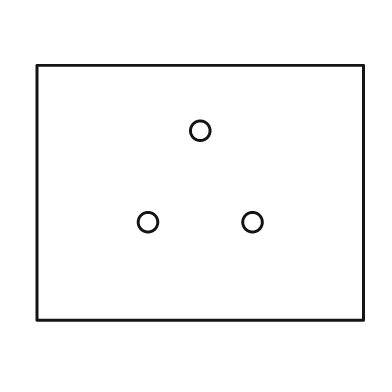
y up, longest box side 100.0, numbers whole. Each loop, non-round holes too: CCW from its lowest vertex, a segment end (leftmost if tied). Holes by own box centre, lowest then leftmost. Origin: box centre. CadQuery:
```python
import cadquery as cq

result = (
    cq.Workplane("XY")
    .moveTo(-50.0, -39.0)
    .lineTo(50.0, -39.0)
    .lineTo(50.0, 39.0)
    .lineTo(-50.0, 39.0)
    .close()
    .moveTo(-16.0, -9.0)
    .circle(3.0)
    .moveTo(16.0, -9.0)
    .circle(3.0)
    .moveTo(0.0, 19.0)
    .circle(3.0)
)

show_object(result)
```